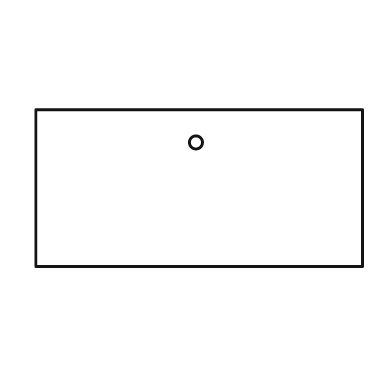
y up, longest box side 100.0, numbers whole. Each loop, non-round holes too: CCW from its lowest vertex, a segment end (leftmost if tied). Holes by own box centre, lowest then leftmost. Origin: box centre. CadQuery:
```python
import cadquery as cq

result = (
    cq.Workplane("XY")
    .moveTo(-50.0, -24.0)
    .lineTo(50.0, -24.0)
    .lineTo(50.0, 24.0)
    .lineTo(-50.0, 24.0)
    .close()
    .moveTo(-1.0, 14.0)
    .circle(2.0)
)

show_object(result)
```